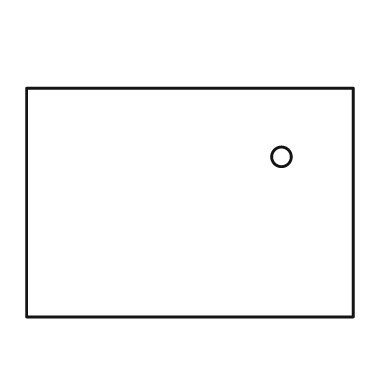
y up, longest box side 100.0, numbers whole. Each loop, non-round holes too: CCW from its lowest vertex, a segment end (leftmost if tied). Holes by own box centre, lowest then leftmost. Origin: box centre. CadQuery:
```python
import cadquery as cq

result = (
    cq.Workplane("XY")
    .moveTo(-50.0, -35.0)
    .lineTo(50.0, -35.0)
    .lineTo(50.0, 35.0)
    .lineTo(-50.0, 35.0)
    .close()
    .moveTo(28.0, 14.0)
    .circle(3.0)
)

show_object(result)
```